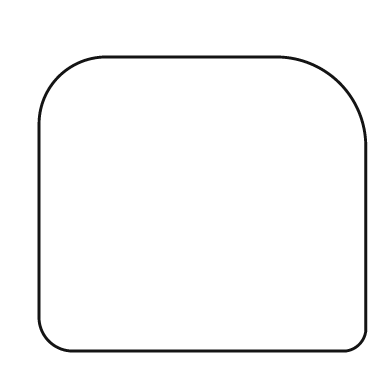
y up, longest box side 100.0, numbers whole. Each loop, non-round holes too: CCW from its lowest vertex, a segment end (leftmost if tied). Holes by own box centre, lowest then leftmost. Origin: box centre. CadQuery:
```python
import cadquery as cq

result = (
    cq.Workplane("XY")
    .moveTo(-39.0, -45.0)
    .lineTo(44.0, -45.0)
    .threePointArc((48.0, -43.0), (50.0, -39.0))
    .lineTo(50.0, 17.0)
    .threePointArc((42.0, 37.0), (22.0, 45.0))
    .lineTo(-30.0, 45.0)
    .threePointArc((-44.0, 39.0), (-50.0, 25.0))
    .lineTo(-50.0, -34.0)
    .threePointArc((-47.0, -42.0), (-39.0, -45.0))
    .close()
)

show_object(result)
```